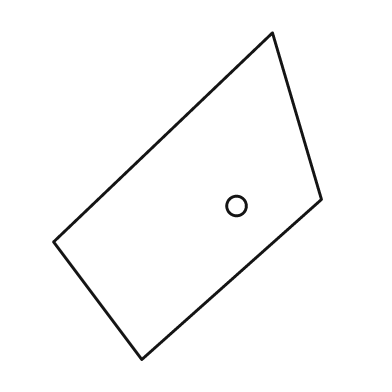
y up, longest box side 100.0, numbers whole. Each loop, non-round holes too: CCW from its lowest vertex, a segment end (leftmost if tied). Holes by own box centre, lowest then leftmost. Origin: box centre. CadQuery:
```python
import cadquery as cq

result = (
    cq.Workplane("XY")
    .moveTo(-14.0, -50.0)
    .lineTo(41.0, -1.0)
    .lineTo(26.0, 50.0)
    .lineTo(-41.0, -14.0)
    .close()
    .moveTo(15.0, -3.0)
    .circle(3.0)
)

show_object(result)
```